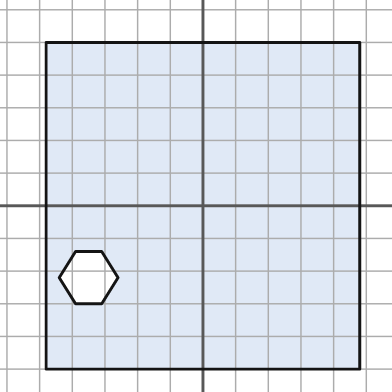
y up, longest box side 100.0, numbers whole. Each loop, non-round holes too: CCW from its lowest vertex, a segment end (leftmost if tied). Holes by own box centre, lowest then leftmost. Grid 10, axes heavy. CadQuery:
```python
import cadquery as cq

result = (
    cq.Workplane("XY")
    .moveTo(-48.0, -50.0)
    .lineTo(48.0, -50.0)
    .lineTo(48.0, 50.0)
    .lineTo(-48.0, 50.0)
    .close()
    .moveTo(-39.0, -30.0)
    .lineTo(-31.0, -30.0)
    .lineTo(-26.0, -22.0)
    .lineTo(-31.0, -14.0)
    .lineTo(-39.0, -14.0)
    .lineTo(-44.0, -22.0)
    .close()
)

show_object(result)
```